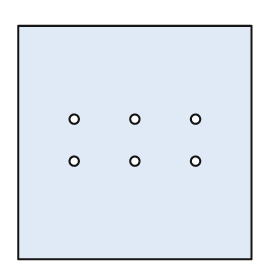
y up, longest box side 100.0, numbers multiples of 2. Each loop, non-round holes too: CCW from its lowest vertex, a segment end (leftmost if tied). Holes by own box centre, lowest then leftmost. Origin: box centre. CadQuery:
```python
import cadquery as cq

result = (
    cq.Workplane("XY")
    .moveTo(-50.0, -50.0)
    .lineTo(50.0, -50.0)
    .lineTo(50.0, 50.0)
    .lineTo(-50.0, 50.0)
    .close()
    .moveTo(-26.0, -8.0)
    .circle(2.0)
    .moveTo(0.0, -8.0)
    .circle(2.0)
    .moveTo(26.0, -8.0)
    .circle(2.0)
    .moveTo(-26.0, 10.0)
    .circle(2.0)
    .moveTo(0.0, 10.0)
    .circle(2.0)
    .moveTo(26.0, 10.0)
    .circle(2.0)
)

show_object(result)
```